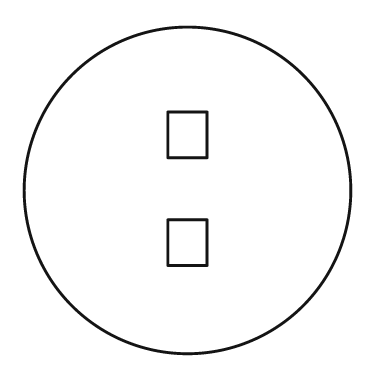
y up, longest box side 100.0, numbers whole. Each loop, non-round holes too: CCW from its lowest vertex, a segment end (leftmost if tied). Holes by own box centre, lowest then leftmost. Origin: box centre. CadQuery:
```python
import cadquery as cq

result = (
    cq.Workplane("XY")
    .moveTo(0.0, 0.0)
    .circle(50.0)
    .moveTo(-6.0, -23.0)
    .lineTo(6.0, -23.0)
    .lineTo(6.0, -9.0)
    .lineTo(-6.0, -9.0)
    .close()
    .moveTo(-6.0, 10.0)
    .lineTo(6.0, 10.0)
    .lineTo(6.0, 24.0)
    .lineTo(-6.0, 24.0)
    .close()
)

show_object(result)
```